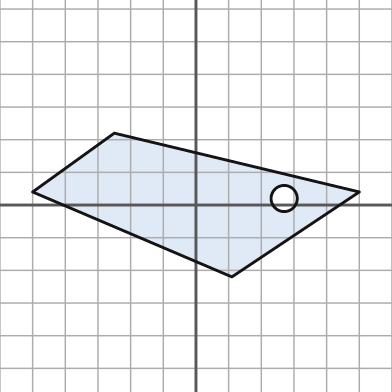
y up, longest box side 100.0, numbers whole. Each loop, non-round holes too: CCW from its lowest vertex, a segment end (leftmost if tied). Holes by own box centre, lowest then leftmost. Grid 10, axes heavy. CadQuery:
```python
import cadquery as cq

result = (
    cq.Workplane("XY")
    .moveTo(11.0, -22.0)
    .lineTo(50.0, 4.0)
    .lineTo(-25.0, 22.0)
    .lineTo(-50.0, 4.0)
    .close()
    .moveTo(27.0, 2.0)
    .circle(4.0)
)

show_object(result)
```